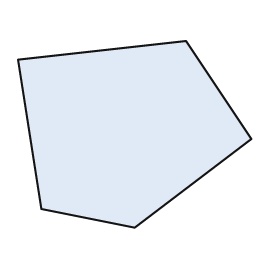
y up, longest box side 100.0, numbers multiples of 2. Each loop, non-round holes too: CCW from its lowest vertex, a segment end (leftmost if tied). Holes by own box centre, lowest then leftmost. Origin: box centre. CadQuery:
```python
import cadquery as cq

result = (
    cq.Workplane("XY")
    .moveTo(0.0, -40.0)
    .lineTo(50.0, -2.0)
    .lineTo(22.0, 40.0)
    .lineTo(-50.0, 32.0)
    .lineTo(-40.0, -32.0)
    .close()
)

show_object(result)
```